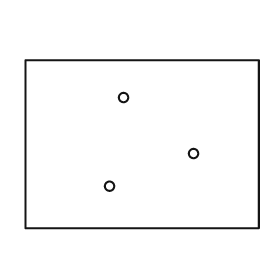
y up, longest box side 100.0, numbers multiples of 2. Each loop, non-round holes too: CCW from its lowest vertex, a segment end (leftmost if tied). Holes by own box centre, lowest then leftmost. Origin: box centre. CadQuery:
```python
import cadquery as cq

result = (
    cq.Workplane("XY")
    .moveTo(-50.0, -36.0)
    .lineTo(50.0, -36.0)
    .lineTo(50.0, 36.0)
    .lineTo(-50.0, 36.0)
    .close()
    .moveTo(-14.0, -18.0)
    .circle(2.0)
    .moveTo(22.0, -4.0)
    .circle(2.0)
    .moveTo(-8.0, 20.0)
    .circle(2.0)
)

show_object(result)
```